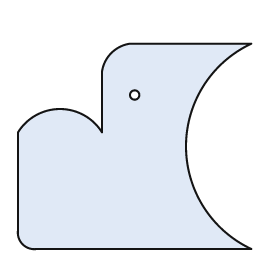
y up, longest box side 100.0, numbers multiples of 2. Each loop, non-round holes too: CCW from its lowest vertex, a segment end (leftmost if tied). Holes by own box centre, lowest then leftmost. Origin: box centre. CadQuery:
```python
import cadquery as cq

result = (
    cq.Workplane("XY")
    .moveTo(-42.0, -44.0)
    .lineTo(50.0, -44.0)
    .threePointArc((22.0, 0.0), (50.0, 44.0))
    .lineTo(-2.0, 44.0)
    .threePointArc((-10.0, 40.0), (-14.0, 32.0))
    .lineTo(-14.0, 6.0)
    .threePointArc((-32.0, 16.0), (-50.0, 6.0))
    .lineTo(-50.0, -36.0)
    .threePointArc((-48.0, -42.0), (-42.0, -44.0))
    .close()
    .moveTo(0.0, 22.0)
    .circle(2.0)
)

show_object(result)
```